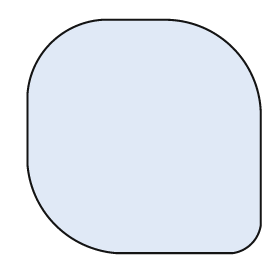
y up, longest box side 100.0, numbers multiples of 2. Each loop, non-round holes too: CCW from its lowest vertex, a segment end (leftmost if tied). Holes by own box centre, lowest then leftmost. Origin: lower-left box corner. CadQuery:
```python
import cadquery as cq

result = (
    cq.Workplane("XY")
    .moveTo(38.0, 0.0)
    .lineTo(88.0, 0.0)
    .threePointArc((96.0, 4.0), (100.0, 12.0))
    .lineTo(100.0, 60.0)
    .threePointArc((88.0, 88.0), (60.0, 100.0))
    .lineTo(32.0, 100.0)
    .threePointArc((10.0, 90.0), (0.0, 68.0))
    .lineTo(0.0, 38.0)
    .threePointArc((12.0, 12.0), (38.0, 0.0))
    .close()
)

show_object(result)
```